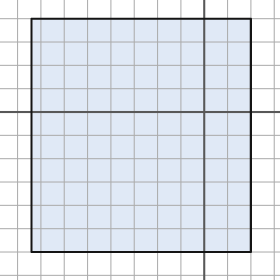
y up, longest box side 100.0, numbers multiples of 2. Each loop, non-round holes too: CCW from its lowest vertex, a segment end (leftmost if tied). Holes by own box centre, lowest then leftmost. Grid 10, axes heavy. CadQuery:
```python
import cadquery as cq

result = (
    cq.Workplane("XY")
    .moveTo(-74.0, -60.0)
    .lineTo(20.0, -60.0)
    .lineTo(20.0, 40.0)
    .lineTo(-74.0, 40.0)
    .close()
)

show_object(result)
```